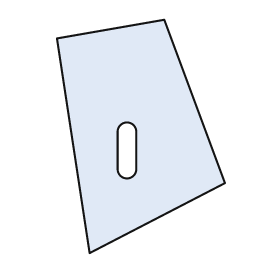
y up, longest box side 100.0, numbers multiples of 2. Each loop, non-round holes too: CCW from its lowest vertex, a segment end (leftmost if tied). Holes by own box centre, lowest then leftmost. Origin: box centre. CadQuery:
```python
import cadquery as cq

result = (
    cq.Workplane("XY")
    .moveTo(-22.0, -50.0)
    .lineTo(36.0, -20.0)
    .lineTo(10.0, 50.0)
    .lineTo(-36.0, 42.0)
    .close()
    .moveTo(-10.0, -14.0)
    .threePointArc((-6.0, -18.0), (-2.0, -14.0))
    .lineTo(-2.0, 2.0)
    .threePointArc((-6.0, 6.0), (-10.0, 2.0))
    .close()
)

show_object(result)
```